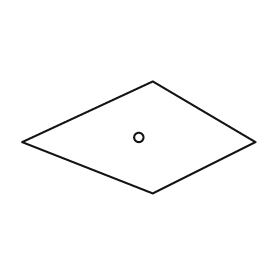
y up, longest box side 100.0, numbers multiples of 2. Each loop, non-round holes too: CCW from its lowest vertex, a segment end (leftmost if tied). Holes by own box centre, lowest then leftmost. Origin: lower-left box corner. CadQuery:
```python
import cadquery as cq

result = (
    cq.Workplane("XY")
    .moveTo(56.0, 0.0)
    .lineTo(100.0, 22.0)
    .lineTo(56.0, 48.0)
    .lineTo(0.0, 22.0)
    .close()
    .moveTo(50.0, 24.0)
    .circle(2.0)
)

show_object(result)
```